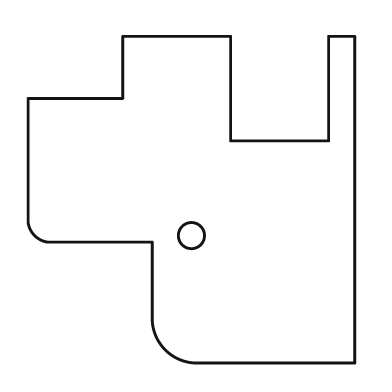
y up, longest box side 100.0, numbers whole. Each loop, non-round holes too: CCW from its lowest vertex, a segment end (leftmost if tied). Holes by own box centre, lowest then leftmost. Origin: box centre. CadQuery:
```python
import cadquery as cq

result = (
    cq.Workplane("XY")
    .moveTo(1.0, -50.0)
    .lineTo(50.0, -50.0)
    .lineTo(50.0, 50.0)
    .lineTo(42.0, 50.0)
    .lineTo(42.0, 18.0)
    .lineTo(12.0, 18.0)
    .lineTo(12.0, 50.0)
    .lineTo(-21.0, 50.0)
    .lineTo(-21.0, 31.0)
    .lineTo(-50.0, 31.0)
    .lineTo(-50.0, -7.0)
    .threePointArc((-48.0, -11.0), (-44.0, -13.0))
    .lineTo(-12.0, -13.0)
    .lineTo(-12.0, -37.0)
    .threePointArc((-8.0, -46.0), (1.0, -50.0))
    .close()
    .moveTo(0.0, -11.0)
    .circle(4.0)
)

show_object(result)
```